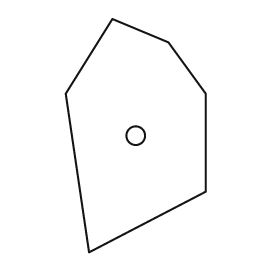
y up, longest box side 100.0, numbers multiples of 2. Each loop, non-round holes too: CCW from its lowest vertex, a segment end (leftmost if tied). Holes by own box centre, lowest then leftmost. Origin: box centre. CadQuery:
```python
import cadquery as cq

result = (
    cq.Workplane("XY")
    .moveTo(-20.0, -50.0)
    .lineTo(30.0, -24.0)
    .lineTo(30.0, 18.0)
    .lineTo(14.0, 40.0)
    .lineTo(-10.0, 50.0)
    .lineTo(-30.0, 18.0)
    .close()
    .moveTo(0.0, 0.0)
    .circle(4.0)
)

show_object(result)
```